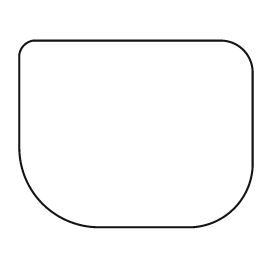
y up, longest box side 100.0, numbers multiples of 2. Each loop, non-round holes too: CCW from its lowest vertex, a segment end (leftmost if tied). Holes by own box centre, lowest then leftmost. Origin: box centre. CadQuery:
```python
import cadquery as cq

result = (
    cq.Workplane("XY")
    .moveTo(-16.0, -40.0)
    .lineTo(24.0, -40.0)
    .threePointArc((42.0, -32.0), (50.0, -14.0))
    .lineTo(50.0, 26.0)
    .threePointArc((46.0, 36.0), (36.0, 40.0))
    .lineTo(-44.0, 40.0)
    .threePointArc((-48.0, 38.0), (-50.0, 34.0))
    .lineTo(-50.0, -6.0)
    .threePointArc((-40.0, -30.0), (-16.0, -40.0))
    .close()
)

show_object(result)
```